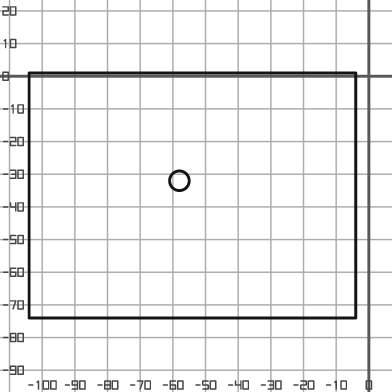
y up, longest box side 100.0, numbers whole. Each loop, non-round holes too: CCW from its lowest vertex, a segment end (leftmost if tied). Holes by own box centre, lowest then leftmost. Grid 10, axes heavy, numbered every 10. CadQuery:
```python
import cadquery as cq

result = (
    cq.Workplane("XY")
    .moveTo(-104.0, -74.0)
    .lineTo(-4.0, -74.0)
    .lineTo(-4.0, 1.0)
    .lineTo(-104.0, 1.0)
    .close()
    .moveTo(-58.0, -32.0)
    .circle(3.0)
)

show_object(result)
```